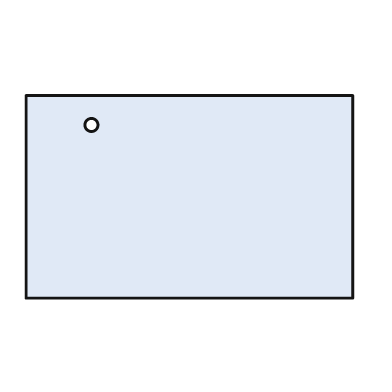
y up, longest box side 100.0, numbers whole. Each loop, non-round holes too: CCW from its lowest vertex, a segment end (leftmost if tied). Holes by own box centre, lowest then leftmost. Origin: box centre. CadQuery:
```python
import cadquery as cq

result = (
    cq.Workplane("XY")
    .moveTo(-50.0, -31.0)
    .lineTo(50.0, -31.0)
    .lineTo(50.0, 31.0)
    .lineTo(-50.0, 31.0)
    .close()
    .moveTo(-30.0, 22.0)
    .circle(2.0)
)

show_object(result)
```